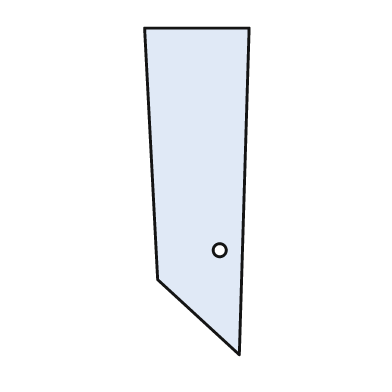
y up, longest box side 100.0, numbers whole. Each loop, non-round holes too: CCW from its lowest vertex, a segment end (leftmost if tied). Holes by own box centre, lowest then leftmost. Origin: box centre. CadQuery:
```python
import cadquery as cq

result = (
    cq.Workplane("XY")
    .moveTo(13.0, -50.0)
    .lineTo(16.0, 50.0)
    .lineTo(-16.0, 50.0)
    .lineTo(-12.0, -27.0)
    .close()
    .moveTo(7.0, -18.0)
    .circle(2.0)
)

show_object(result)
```